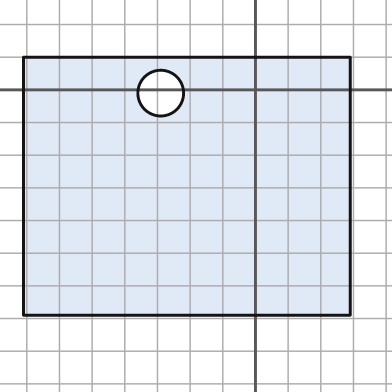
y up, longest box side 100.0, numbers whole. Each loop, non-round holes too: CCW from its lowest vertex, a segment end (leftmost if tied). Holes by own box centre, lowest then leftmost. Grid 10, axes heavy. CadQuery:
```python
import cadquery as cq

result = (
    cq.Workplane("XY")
    .moveTo(-71.0, -69.0)
    .lineTo(29.0, -69.0)
    .lineTo(29.0, 10.0)
    .lineTo(-71.0, 10.0)
    .close()
    .moveTo(-29.0, -1.0)
    .circle(7.0)
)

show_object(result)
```